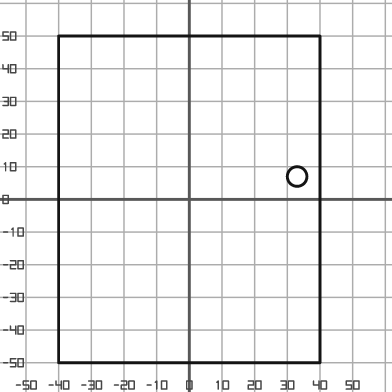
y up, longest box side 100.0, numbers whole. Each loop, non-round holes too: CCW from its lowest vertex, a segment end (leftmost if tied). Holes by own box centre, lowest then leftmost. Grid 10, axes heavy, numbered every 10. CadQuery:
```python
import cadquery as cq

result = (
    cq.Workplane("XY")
    .moveTo(-40.0, -50.0)
    .lineTo(40.0, -50.0)
    .lineTo(40.0, 50.0)
    .lineTo(-40.0, 50.0)
    .close()
    .moveTo(33.0, 7.0)
    .circle(3.0)
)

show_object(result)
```